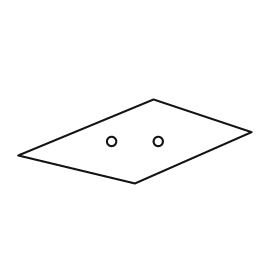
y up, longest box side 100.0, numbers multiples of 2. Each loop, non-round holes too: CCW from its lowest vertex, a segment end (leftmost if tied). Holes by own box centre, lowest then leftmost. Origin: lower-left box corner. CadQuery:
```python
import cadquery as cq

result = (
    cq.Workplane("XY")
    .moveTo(50.0, 0.0)
    .lineTo(100.0, 22.0)
    .lineTo(58.0, 36.0)
    .lineTo(0.0, 12.0)
    .close()
    .moveTo(40.0, 18.0)
    .circle(2.0)
    .moveTo(60.0, 18.0)
    .circle(2.0)
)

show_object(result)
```